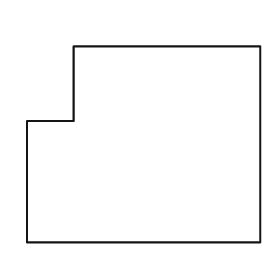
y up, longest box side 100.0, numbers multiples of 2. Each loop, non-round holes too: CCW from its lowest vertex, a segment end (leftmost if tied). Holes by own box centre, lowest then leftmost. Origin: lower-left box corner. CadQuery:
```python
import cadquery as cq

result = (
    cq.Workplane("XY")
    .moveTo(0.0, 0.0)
    .lineTo(100.0, 0.0)
    .lineTo(100.0, 84.0)
    .lineTo(20.0, 84.0)
    .lineTo(20.0, 52.0)
    .lineTo(0.0, 52.0)
    .close()
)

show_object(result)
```